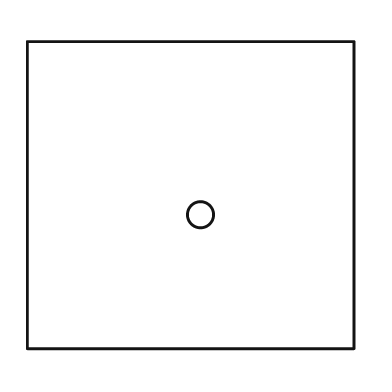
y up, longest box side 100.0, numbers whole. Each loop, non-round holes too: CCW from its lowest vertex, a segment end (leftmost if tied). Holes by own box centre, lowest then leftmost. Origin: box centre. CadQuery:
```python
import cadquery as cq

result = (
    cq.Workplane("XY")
    .moveTo(-50.0, -47.0)
    .lineTo(50.0, -47.0)
    .lineTo(50.0, 47.0)
    .lineTo(-50.0, 47.0)
    .close()
    .moveTo(3.0, -6.0)
    .circle(4.0)
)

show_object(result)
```